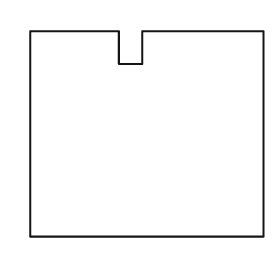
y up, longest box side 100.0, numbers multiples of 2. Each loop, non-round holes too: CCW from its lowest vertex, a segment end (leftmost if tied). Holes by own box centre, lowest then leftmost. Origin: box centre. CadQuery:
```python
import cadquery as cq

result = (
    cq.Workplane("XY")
    .moveTo(-50.0, -44.0)
    .lineTo(50.0, -44.0)
    .lineTo(50.0, 44.0)
    .lineTo(-2.0, 44.0)
    .lineTo(-2.0, 30.0)
    .lineTo(-12.0, 30.0)
    .lineTo(-12.0, 44.0)
    .lineTo(-50.0, 44.0)
    .close()
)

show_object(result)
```